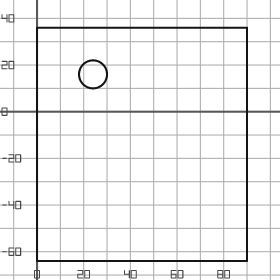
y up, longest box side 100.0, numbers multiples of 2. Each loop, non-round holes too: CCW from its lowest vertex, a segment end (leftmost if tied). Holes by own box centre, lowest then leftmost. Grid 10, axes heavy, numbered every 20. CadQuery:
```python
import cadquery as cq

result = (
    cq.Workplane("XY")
    .moveTo(0.0, -64.0)
    .lineTo(90.0, -64.0)
    .lineTo(90.0, 36.0)
    .lineTo(0.0, 36.0)
    .close()
    .moveTo(24.0, 16.0)
    .circle(6.0)
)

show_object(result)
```